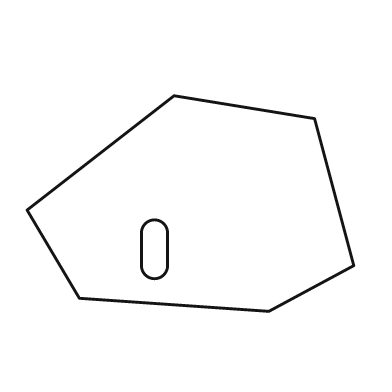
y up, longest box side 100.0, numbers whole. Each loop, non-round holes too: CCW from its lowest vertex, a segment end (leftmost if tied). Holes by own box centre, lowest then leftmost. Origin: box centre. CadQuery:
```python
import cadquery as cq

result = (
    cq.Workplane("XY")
    .moveTo(24.0, -33.0)
    .lineTo(50.0, -19.0)
    .lineTo(38.0, 26.0)
    .lineTo(-5.0, 33.0)
    .lineTo(-50.0, -2.0)
    .lineTo(-34.0, -29.0)
    .close()
    .moveTo(-15.0, -19.0)
    .threePointArc((-11.0, -23.0), (-7.0, -19.0))
    .lineTo(-7.0, -9.0)
    .threePointArc((-11.0, -5.0), (-15.0, -9.0))
    .close()
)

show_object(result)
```